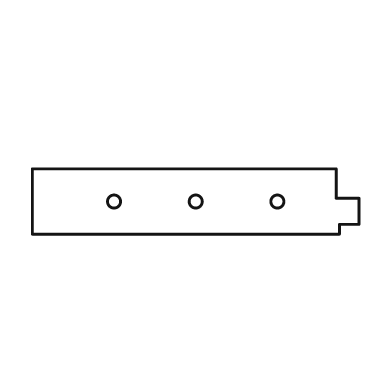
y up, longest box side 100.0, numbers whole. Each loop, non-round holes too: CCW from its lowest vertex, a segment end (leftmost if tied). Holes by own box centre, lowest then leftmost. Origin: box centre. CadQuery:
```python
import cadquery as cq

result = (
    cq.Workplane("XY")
    .moveTo(-50.0, -10.0)
    .lineTo(44.0, -10.0)
    .lineTo(44.0, -7.0)
    .lineTo(50.0, -7.0)
    .lineTo(50.0, 1.0)
    .lineTo(43.0, 1.0)
    .lineTo(43.0, 10.0)
    .lineTo(-50.0, 10.0)
    .close()
    .moveTo(-25.0, 0.0)
    .circle(2.0)
    .moveTo(0.0, 0.0)
    .circle(2.0)
    .moveTo(25.0, 0.0)
    .circle(2.0)
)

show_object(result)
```